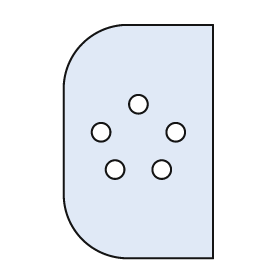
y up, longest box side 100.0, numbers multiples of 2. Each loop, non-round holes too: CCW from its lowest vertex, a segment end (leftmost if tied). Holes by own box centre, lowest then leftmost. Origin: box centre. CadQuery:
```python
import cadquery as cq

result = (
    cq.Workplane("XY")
    .moveTo(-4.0, -50.0)
    .lineTo(32.0, -50.0)
    .lineTo(32.0, 50.0)
    .lineTo(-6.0, 50.0)
    .threePointArc((-24.0, 42.0), (-32.0, 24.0))
    .lineTo(-32.0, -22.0)
    .threePointArc((-24.0, -42.0), (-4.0, -50.0))
    .close()
    .moveTo(-10.0, -12.0)
    .circle(4.0)
    .moveTo(10.0, -12.0)
    .circle(4.0)
    .moveTo(-16.0, 4.0)
    .circle(4.0)
    .moveTo(16.0, 4.0)
    .circle(4.0)
    .moveTo(0.0, 16.0)
    .circle(4.0)
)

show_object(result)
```